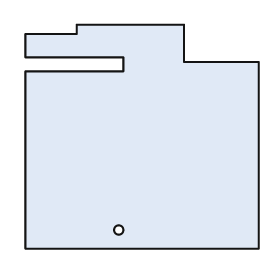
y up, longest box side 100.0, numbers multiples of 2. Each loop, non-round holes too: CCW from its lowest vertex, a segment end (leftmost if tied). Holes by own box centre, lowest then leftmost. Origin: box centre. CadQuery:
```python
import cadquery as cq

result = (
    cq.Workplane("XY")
    .moveTo(-50.0, -48.0)
    .lineTo(50.0, -48.0)
    .lineTo(50.0, 32.0)
    .lineTo(18.0, 32.0)
    .lineTo(18.0, 48.0)
    .lineTo(-28.0, 48.0)
    .lineTo(-28.0, 44.0)
    .lineTo(-50.0, 44.0)
    .lineTo(-50.0, 34.0)
    .lineTo(-8.0, 34.0)
    .lineTo(-8.0, 28.0)
    .lineTo(-50.0, 28.0)
    .close()
    .moveTo(-10.0, -40.0)
    .circle(2.0)
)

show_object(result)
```